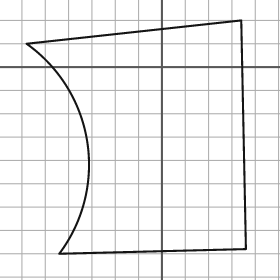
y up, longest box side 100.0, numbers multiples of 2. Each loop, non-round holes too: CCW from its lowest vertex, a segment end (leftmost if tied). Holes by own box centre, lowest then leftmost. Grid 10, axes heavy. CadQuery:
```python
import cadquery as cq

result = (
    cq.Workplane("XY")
    .moveTo(-44.0, -80.0)
    .lineTo(36.0, -78.0)
    .lineTo(34.0, 20.0)
    .lineTo(-58.0, 10.0)
    .threePointArc((-32.0, -32.0), (-44.0, -80.0))
    .close()
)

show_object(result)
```